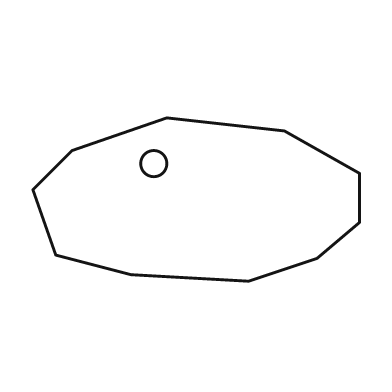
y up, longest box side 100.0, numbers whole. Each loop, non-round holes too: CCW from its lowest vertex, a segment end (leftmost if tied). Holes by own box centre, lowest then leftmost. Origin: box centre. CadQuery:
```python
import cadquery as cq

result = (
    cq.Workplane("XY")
    .moveTo(16.0, -25.0)
    .lineTo(37.0, -18.0)
    .lineTo(50.0, -7.0)
    .lineTo(50.0, 8.0)
    .lineTo(27.0, 21.0)
    .lineTo(-9.0, 25.0)
    .lineTo(-38.0, 15.0)
    .lineTo(-50.0, 3.0)
    .lineTo(-43.0, -17.0)
    .lineTo(-20.0, -23.0)
    .close()
    .moveTo(-13.0, 11.0)
    .circle(4.0)
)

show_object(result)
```